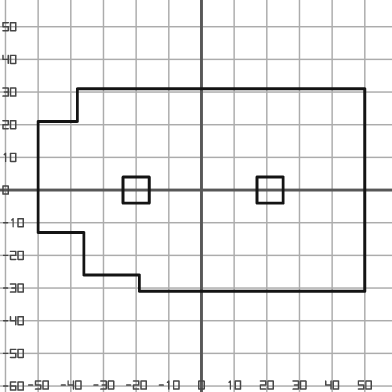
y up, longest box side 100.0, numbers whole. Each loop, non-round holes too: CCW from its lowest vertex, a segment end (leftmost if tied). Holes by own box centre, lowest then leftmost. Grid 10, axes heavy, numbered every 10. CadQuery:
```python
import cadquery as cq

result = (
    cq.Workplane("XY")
    .moveTo(-19.0, -31.0)
    .lineTo(50.0, -31.0)
    .lineTo(50.0, 31.0)
    .lineTo(-38.0, 31.0)
    .lineTo(-38.0, 21.0)
    .lineTo(-50.0, 21.0)
    .lineTo(-50.0, -13.0)
    .lineTo(-36.0, -13.0)
    .lineTo(-36.0, -26.0)
    .lineTo(-19.0, -26.0)
    .close()
    .moveTo(-24.0, -4.0)
    .lineTo(-16.0, -4.0)
    .lineTo(-16.0, 4.0)
    .lineTo(-24.0, 4.0)
    .close()
    .moveTo(17.0, -4.0)
    .lineTo(25.0, -4.0)
    .lineTo(25.0, 4.0)
    .lineTo(17.0, 4.0)
    .close()
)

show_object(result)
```